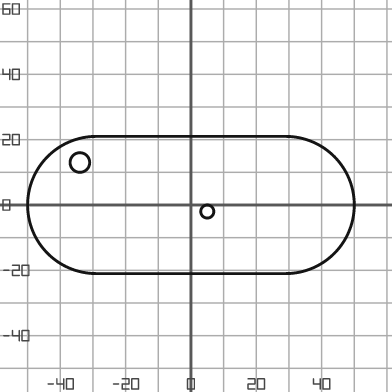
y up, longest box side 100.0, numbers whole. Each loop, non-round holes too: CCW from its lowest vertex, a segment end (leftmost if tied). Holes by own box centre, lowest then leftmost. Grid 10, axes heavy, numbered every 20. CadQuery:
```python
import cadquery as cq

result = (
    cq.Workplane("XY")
    .moveTo(-29.0, -21.0)
    .lineTo(29.0, -21.0)
    .threePointArc((50.0, 0.0), (29.0, 21.0))
    .lineTo(-29.0, 21.0)
    .threePointArc((-50.0, 0.0), (-29.0, -21.0))
    .close()
    .moveTo(5.0, -2.0)
    .circle(2.0)
    .moveTo(-34.0, 13.0)
    .circle(3.0)
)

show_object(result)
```